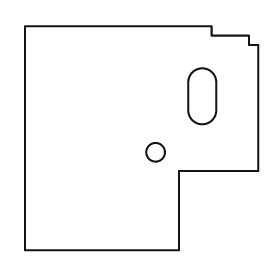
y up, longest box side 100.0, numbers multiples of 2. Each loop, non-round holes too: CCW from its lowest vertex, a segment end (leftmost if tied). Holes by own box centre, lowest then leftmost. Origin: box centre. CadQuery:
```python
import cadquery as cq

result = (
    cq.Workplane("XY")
    .moveTo(-50.0, -48.0)
    .lineTo(16.0, -48.0)
    .lineTo(16.0, -14.0)
    .lineTo(50.0, -14.0)
    .lineTo(50.0, 40.0)
    .lineTo(46.0, 40.0)
    .lineTo(46.0, 44.0)
    .lineTo(30.0, 44.0)
    .lineTo(30.0, 48.0)
    .lineTo(-50.0, 48.0)
    .close()
    .moveTo(6.0, -6.0)
    .circle(4.0)
    .moveTo(20.0, 12.0)
    .threePointArc((26.0, 6.0), (32.0, 12.0))
    .lineTo(32.0, 24.0)
    .threePointArc((26.0, 30.0), (20.0, 24.0))
    .close()
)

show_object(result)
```